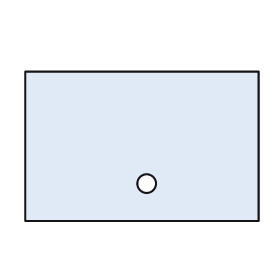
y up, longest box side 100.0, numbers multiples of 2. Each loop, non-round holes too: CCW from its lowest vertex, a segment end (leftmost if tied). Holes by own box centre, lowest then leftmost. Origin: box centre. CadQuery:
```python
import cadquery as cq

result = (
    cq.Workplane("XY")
    .moveTo(-50.0, -32.0)
    .lineTo(50.0, -32.0)
    .lineTo(50.0, 32.0)
    .lineTo(-50.0, 32.0)
    .close()
    .moveTo(2.0, -16.0)
    .circle(4.0)
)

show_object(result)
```